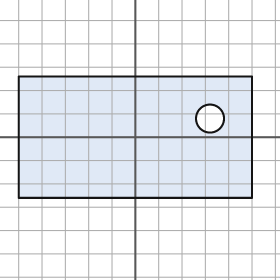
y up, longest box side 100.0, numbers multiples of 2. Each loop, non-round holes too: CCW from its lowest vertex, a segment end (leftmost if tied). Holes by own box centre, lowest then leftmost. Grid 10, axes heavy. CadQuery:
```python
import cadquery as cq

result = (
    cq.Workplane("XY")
    .moveTo(-50.0, -26.0)
    .lineTo(50.0, -26.0)
    .lineTo(50.0, 26.0)
    .lineTo(-50.0, 26.0)
    .close()
    .moveTo(32.0, 8.0)
    .circle(6.0)
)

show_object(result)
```